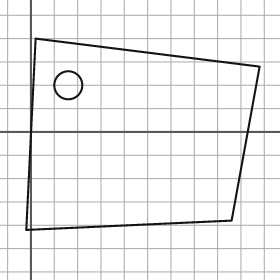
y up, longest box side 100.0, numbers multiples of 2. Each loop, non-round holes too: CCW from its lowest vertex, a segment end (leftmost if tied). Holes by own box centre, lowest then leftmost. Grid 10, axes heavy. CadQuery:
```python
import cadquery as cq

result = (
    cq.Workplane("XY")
    .moveTo(-2.0, -42.0)
    .lineTo(86.0, -38.0)
    .lineTo(98.0, 28.0)
    .lineTo(2.0, 40.0)
    .close()
    .moveTo(16.0, 20.0)
    .circle(6.0)
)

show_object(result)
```